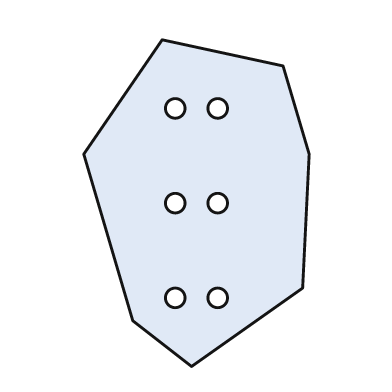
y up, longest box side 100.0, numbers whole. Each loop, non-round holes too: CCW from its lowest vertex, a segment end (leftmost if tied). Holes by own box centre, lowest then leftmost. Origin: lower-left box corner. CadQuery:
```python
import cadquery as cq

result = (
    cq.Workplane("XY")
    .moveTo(33.0, 0.0)
    .lineTo(67.0, 24.0)
    .lineTo(69.0, 65.0)
    .lineTo(61.0, 92.0)
    .lineTo(24.0, 100.0)
    .lineTo(0.0, 65.0)
    .lineTo(15.0, 14.0)
    .close()
    .moveTo(28.0, 21.0)
    .circle(3.0)
    .moveTo(41.0, 21.0)
    .circle(3.0)
    .moveTo(28.0, 50.0)
    .circle(3.0)
    .moveTo(41.0, 50.0)
    .circle(3.0)
    .moveTo(28.0, 79.0)
    .circle(3.0)
    .moveTo(41.0, 79.0)
    .circle(3.0)
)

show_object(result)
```